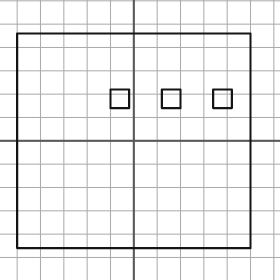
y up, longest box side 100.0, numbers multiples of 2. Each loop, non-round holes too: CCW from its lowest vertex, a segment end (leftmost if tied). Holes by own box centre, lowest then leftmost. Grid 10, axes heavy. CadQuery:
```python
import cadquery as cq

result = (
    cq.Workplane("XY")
    .moveTo(-50.0, -46.0)
    .lineTo(50.0, -46.0)
    .lineTo(50.0, 46.0)
    .lineTo(-50.0, 46.0)
    .close()
    .moveTo(-10.0, 14.0)
    .lineTo(-2.0, 14.0)
    .lineTo(-2.0, 22.0)
    .lineTo(-10.0, 22.0)
    .close()
    .moveTo(12.0, 14.0)
    .lineTo(20.0, 14.0)
    .lineTo(20.0, 22.0)
    .lineTo(12.0, 22.0)
    .close()
    .moveTo(34.0, 14.0)
    .lineTo(42.0, 14.0)
    .lineTo(42.0, 22.0)
    .lineTo(34.0, 22.0)
    .close()
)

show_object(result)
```